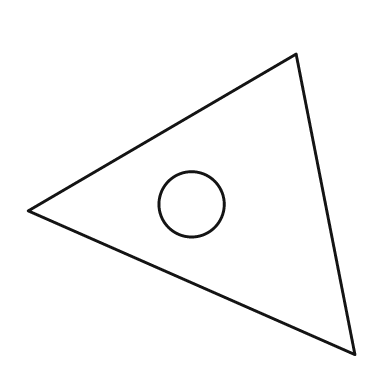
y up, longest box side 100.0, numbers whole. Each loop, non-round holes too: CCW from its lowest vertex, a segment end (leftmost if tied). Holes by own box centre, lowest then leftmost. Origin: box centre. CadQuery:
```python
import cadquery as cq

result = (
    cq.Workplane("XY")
    .moveTo(50.0, -46.0)
    .lineTo(32.0, 46.0)
    .lineTo(-50.0, -2.0)
    .close()
    .moveTo(0.0, 0.0)
    .circle(10.0)
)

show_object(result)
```